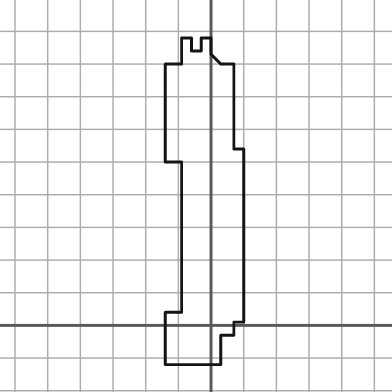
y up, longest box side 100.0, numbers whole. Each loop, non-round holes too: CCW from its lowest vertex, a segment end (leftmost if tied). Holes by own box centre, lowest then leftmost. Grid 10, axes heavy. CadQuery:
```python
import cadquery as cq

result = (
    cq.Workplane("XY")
    .moveTo(-14.0, -12.0)
    .lineTo(3.0, -12.0)
    .lineTo(3.0, -3.0)
    .lineTo(7.0, -3.0)
    .lineTo(7.0, 1.0)
    .lineTo(10.0, 1.0)
    .lineTo(10.0, 54.0)
    .lineTo(7.0, 54.0)
    .lineTo(7.0, 80.0)
    .lineTo(3.0, 80.0)
    .lineTo(0.0, 83.0)
    .lineTo(0.0, 88.0)
    .lineTo(-3.0, 88.0)
    .lineTo(-3.0, 84.0)
    .lineTo(-6.0, 84.0)
    .lineTo(-6.0, 88.0)
    .lineTo(-9.0, 88.0)
    .lineTo(-9.0, 80.0)
    .lineTo(-14.0, 80.0)
    .lineTo(-14.0, 50.0)
    .lineTo(-9.0, 50.0)
    .lineTo(-9.0, 4.0)
    .lineTo(-14.0, 4.0)
    .close()
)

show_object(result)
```